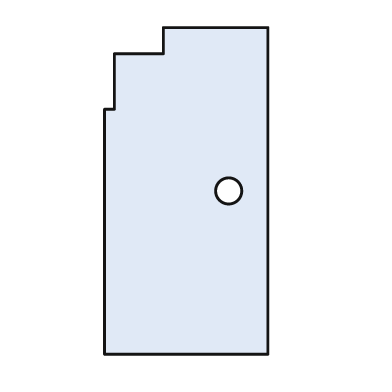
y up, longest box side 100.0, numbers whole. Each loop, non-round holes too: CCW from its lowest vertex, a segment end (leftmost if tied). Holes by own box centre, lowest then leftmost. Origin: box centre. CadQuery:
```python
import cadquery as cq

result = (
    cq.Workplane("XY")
    .moveTo(-25.0, -50.0)
    .lineTo(25.0, -50.0)
    .lineTo(25.0, 50.0)
    .lineTo(-7.0, 50.0)
    .lineTo(-7.0, 42.0)
    .lineTo(-22.0, 42.0)
    .lineTo(-22.0, 25.0)
    .lineTo(-25.0, 25.0)
    .close()
    .moveTo(13.0, 0.0)
    .circle(4.0)
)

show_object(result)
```